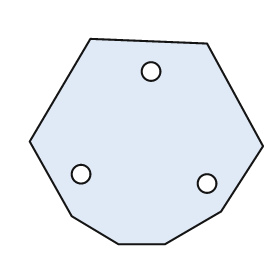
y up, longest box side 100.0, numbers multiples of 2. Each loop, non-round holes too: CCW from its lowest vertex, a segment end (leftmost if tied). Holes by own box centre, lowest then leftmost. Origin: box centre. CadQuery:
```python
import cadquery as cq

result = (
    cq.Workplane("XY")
    .moveTo(-12.0, -44.0)
    .lineTo(8.0, -44.0)
    .lineTo(32.0, -30.0)
    .lineTo(50.0, -2.0)
    .lineTo(26.0, 42.0)
    .lineTo(-24.0, 44.0)
    .lineTo(-50.0, 0.0)
    .lineTo(-32.0, -32.0)
    .close()
    .moveTo(26.0, -18.0)
    .circle(4.0)
    .moveTo(-28.0, -14.0)
    .circle(4.0)
    .moveTo(2.0, 30.0)
    .circle(4.0)
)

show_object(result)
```